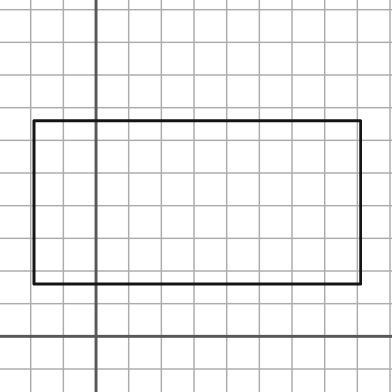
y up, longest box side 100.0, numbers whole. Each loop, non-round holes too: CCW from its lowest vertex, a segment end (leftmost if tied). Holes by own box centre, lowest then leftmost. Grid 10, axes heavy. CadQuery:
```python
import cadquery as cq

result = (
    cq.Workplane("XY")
    .moveTo(-19.0, 16.0)
    .lineTo(81.0, 16.0)
    .lineTo(81.0, 66.0)
    .lineTo(-19.0, 66.0)
    .close()
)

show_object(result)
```